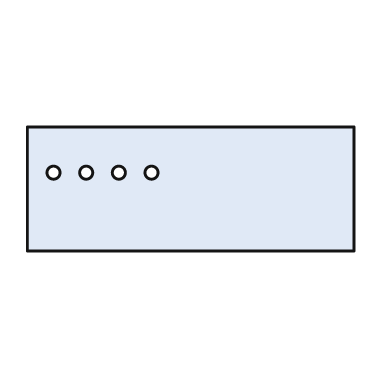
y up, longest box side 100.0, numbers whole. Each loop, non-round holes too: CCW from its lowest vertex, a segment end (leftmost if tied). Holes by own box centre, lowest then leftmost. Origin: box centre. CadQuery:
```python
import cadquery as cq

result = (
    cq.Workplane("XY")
    .moveTo(-50.0, -19.0)
    .lineTo(50.0, -19.0)
    .lineTo(50.0, 19.0)
    .lineTo(-50.0, 19.0)
    .close()
    .moveTo(-42.0, 5.0)
    .circle(2.0)
    .moveTo(-32.0, 5.0)
    .circle(2.0)
    .moveTo(-22.0, 5.0)
    .circle(2.0)
    .moveTo(-12.0, 5.0)
    .circle(2.0)
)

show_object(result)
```